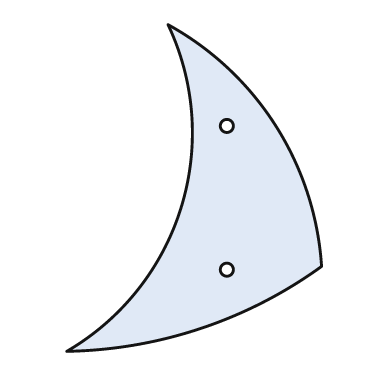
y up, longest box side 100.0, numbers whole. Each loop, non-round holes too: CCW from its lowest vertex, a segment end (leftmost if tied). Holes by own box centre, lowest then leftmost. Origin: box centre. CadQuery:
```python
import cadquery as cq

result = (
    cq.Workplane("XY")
    .moveTo(-39.0, -50.0)
    .threePointArc((2.0, -43.0), (39.0, -24.0))
    .threePointArc((25.0, 19.0), (-8.0, 50.0))
    .threePointArc((-4.0, -6.0), (-39.0, -50.0))
    .close()
    .moveTo(10.0, -25.0)
    .circle(2.0)
    .moveTo(10.0, 19.0)
    .circle(2.0)
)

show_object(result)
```